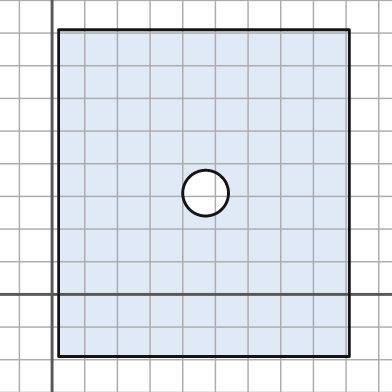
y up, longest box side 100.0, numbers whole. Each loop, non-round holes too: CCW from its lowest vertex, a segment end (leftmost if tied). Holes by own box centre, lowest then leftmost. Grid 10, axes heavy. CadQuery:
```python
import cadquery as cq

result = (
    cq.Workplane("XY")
    .moveTo(2.0, -19.0)
    .lineTo(91.0, -19.0)
    .lineTo(91.0, 81.0)
    .lineTo(2.0, 81.0)
    .close()
    .moveTo(47.0, 31.0)
    .circle(7.0)
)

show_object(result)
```